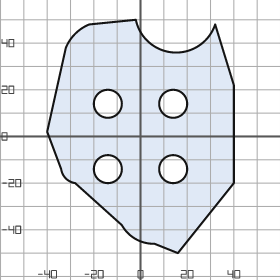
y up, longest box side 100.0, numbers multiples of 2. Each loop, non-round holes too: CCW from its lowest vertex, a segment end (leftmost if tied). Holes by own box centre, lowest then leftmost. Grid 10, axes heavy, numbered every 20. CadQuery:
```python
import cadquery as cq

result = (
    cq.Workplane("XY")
    .moveTo(16.0, -50.0)
    .lineTo(40.0, -20.0)
    .lineTo(40.0, 22.0)
    .lineTo(32.0, 48.0)
    .threePointArc((14.0, 36.0), (-2.0, 50.0))
    .lineTo(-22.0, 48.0)
    .threePointArc((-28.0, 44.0), (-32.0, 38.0))
    .lineTo(-40.0, 2.0)
    .lineTo(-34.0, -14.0)
    .threePointArc((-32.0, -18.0), (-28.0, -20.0))
    .lineTo(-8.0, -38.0)
    .threePointArc((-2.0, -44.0), (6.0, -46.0))
    .close()
    .moveTo(-14.0, -14.0)
    .circle(6.0)
    .moveTo(14.0, -14.0)
    .circle(6.0)
    .moveTo(-14.0, 14.0)
    .circle(6.0)
    .moveTo(14.0, 14.0)
    .circle(6.0)
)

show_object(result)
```